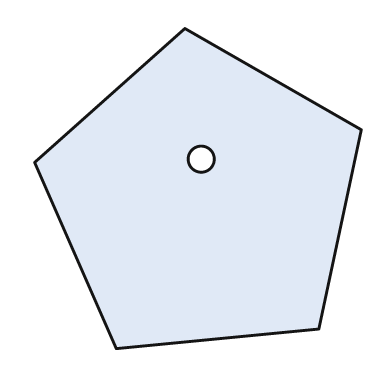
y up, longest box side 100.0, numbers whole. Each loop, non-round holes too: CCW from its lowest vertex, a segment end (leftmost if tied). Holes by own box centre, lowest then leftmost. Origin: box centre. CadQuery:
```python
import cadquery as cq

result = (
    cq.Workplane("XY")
    .moveTo(-25.0, -49.0)
    .lineTo(37.0, -43.0)
    .lineTo(50.0, 18.0)
    .lineTo(-4.0, 49.0)
    .lineTo(-50.0, 8.0)
    .close()
    .moveTo(1.0, 9.0)
    .circle(4.0)
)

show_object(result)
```